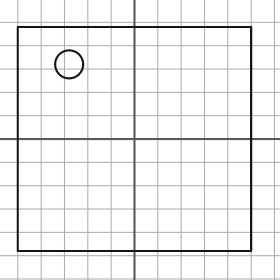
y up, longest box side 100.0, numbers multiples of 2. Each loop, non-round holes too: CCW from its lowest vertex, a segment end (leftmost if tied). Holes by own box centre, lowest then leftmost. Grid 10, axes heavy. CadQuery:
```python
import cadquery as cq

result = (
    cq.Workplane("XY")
    .moveTo(-50.0, -48.0)
    .lineTo(50.0, -48.0)
    .lineTo(50.0, 48.0)
    .lineTo(-50.0, 48.0)
    .close()
    .moveTo(-28.0, 32.0)
    .circle(6.0)
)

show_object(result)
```